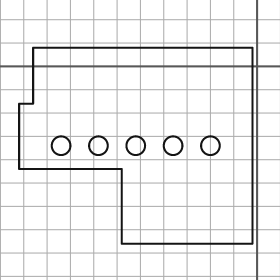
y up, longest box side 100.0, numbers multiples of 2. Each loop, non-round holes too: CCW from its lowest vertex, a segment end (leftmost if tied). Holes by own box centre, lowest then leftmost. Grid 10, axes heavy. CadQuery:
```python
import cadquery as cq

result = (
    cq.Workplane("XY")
    .moveTo(-58.0, -76.0)
    .lineTo(-2.0, -76.0)
    .lineTo(-2.0, 8.0)
    .lineTo(-96.0, 8.0)
    .lineTo(-96.0, -16.0)
    .lineTo(-102.0, -16.0)
    .lineTo(-102.0, -44.0)
    .lineTo(-58.0, -44.0)
    .close()
    .moveTo(-84.0, -34.0)
    .circle(4.0)
    .moveTo(-68.0, -34.0)
    .circle(4.0)
    .moveTo(-52.0, -34.0)
    .circle(4.0)
    .moveTo(-36.0, -34.0)
    .circle(4.0)
    .moveTo(-20.0, -34.0)
    .circle(4.0)
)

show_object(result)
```